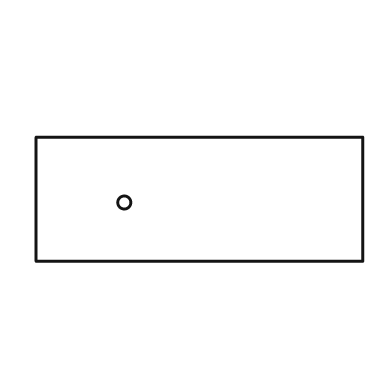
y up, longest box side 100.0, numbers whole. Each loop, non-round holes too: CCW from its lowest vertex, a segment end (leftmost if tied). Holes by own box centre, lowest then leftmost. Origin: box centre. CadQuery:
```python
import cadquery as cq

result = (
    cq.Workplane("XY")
    .moveTo(-50.0, -19.0)
    .lineTo(50.0, -19.0)
    .lineTo(50.0, 19.0)
    .lineTo(-50.0, 19.0)
    .close()
    .moveTo(-23.0, -1.0)
    .circle(2.0)
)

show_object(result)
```